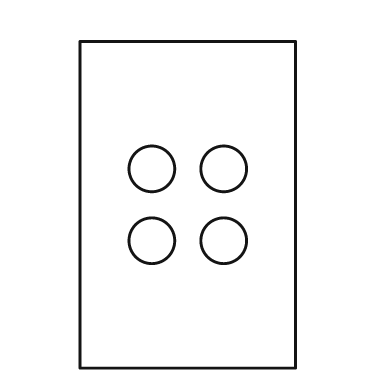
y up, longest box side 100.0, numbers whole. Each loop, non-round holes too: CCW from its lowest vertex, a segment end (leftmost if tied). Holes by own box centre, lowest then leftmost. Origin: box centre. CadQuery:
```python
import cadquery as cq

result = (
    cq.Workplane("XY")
    .moveTo(-33.0, -50.0)
    .lineTo(33.0, -50.0)
    .lineTo(33.0, 50.0)
    .lineTo(-33.0, 50.0)
    .close()
    .moveTo(-11.0, -11.0)
    .circle(7.0)
    .moveTo(11.0, -11.0)
    .circle(7.0)
    .moveTo(-11.0, 11.0)
    .circle(7.0)
    .moveTo(11.0, 11.0)
    .circle(7.0)
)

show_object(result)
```